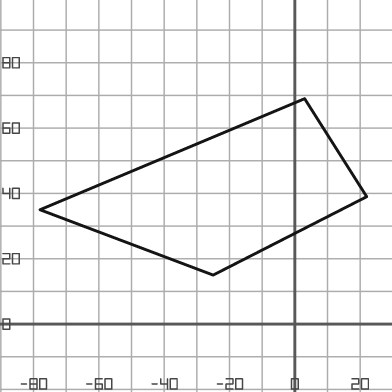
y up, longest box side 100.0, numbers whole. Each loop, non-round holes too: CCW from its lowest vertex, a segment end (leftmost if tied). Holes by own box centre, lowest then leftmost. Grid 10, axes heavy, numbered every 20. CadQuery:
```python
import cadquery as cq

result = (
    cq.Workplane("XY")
    .moveTo(-25.0, 15.0)
    .lineTo(22.0, 39.0)
    .lineTo(3.0, 69.0)
    .lineTo(-78.0, 35.0)
    .close()
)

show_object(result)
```